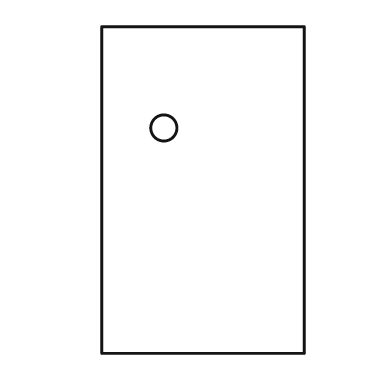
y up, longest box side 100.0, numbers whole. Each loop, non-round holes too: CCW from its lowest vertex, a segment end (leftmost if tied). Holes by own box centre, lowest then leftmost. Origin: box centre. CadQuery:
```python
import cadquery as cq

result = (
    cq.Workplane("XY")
    .moveTo(-31.0, -50.0)
    .lineTo(31.0, -50.0)
    .lineTo(31.0, 50.0)
    .lineTo(-31.0, 50.0)
    .close()
    .moveTo(-12.0, 19.0)
    .circle(4.0)
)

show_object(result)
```